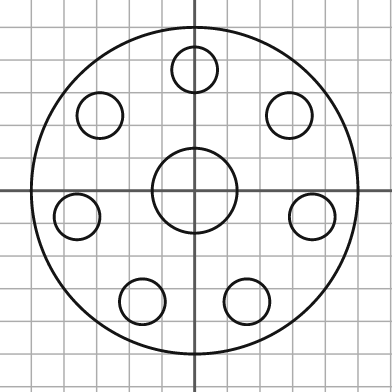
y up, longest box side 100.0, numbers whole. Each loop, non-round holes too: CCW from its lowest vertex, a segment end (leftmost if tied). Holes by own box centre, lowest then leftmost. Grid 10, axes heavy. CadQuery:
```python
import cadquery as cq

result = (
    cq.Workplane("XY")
    .moveTo(0.0, 0.0)
    .circle(50.0)
    .moveTo(-16.0, -34.0)
    .circle(7.0)
    .moveTo(16.0, -34.0)
    .circle(7.0)
    .moveTo(-36.0, -8.0)
    .circle(7.0)
    .moveTo(36.0, -8.0)
    .circle(7.0)
    .moveTo(0.0, 0.0)
    .circle(13.0)
    .moveTo(-29.0, 23.0)
    .circle(7.0)
    .moveTo(29.0, 23.0)
    .circle(7.0)
    .moveTo(0.0, 37.0)
    .circle(7.0)
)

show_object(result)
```